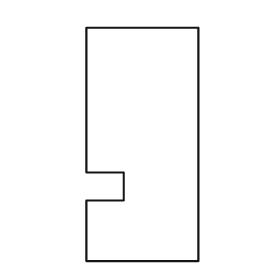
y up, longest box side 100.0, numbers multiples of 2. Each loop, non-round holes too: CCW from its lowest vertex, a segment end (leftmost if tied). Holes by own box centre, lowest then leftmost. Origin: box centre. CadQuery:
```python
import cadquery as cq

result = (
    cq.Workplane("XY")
    .moveTo(-24.0, -50.0)
    .lineTo(24.0, -50.0)
    .lineTo(24.0, 50.0)
    .lineTo(-24.0, 50.0)
    .lineTo(-24.0, -12.0)
    .lineTo(-8.0, -12.0)
    .lineTo(-8.0, -24.0)
    .lineTo(-24.0, -24.0)
    .close()
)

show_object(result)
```